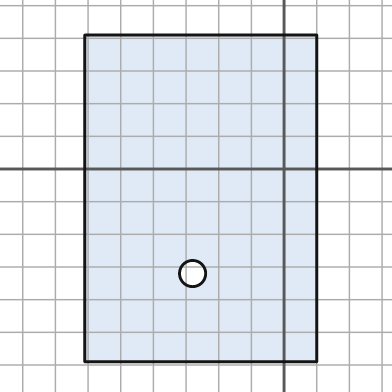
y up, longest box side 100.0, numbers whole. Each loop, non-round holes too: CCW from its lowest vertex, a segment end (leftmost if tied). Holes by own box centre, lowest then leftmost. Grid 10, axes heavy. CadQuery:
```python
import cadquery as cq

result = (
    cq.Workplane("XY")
    .moveTo(-61.0, -59.0)
    .lineTo(10.0, -59.0)
    .lineTo(10.0, 41.0)
    .lineTo(-61.0, 41.0)
    .close()
    .moveTo(-28.0, -32.0)
    .circle(4.0)
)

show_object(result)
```